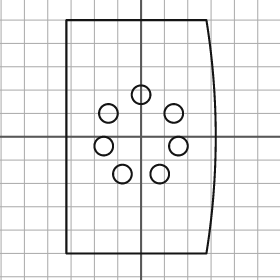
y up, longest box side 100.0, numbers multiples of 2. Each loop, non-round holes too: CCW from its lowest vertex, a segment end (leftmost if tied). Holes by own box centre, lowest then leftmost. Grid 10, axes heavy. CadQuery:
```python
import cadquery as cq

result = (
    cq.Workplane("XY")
    .moveTo(-32.0, -50.0)
    .lineTo(28.0, -50.0)
    .threePointArc((32.0, 0.0), (28.0, 50.0))
    .lineTo(-32.0, 50.0)
    .close()
    .moveTo(-8.0, -16.0)
    .circle(4.0)
    .moveTo(8.0, -16.0)
    .circle(4.0)
    .moveTo(-16.0, -4.0)
    .circle(4.0)
    .moveTo(16.0, -4.0)
    .circle(4.0)
    .moveTo(-14.0, 10.0)
    .circle(4.0)
    .moveTo(14.0, 10.0)
    .circle(4.0)
    .moveTo(0.0, 18.0)
    .circle(4.0)
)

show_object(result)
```